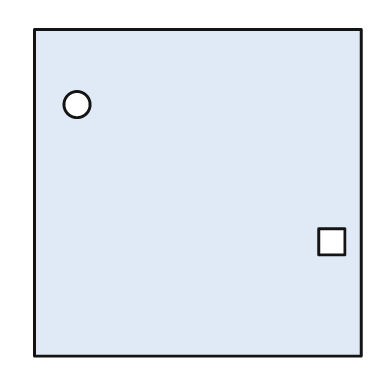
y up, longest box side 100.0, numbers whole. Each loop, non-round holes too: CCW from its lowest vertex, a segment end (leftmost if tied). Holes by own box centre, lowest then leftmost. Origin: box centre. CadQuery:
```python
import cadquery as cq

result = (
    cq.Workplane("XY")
    .moveTo(-50.0, -50.0)
    .lineTo(50.0, -50.0)
    .lineTo(50.0, 50.0)
    .lineTo(-50.0, 50.0)
    .close()
    .moveTo(37.0, -19.0)
    .lineTo(45.0, -19.0)
    .lineTo(45.0, -11.0)
    .lineTo(37.0, -11.0)
    .close()
    .moveTo(-37.0, 27.0)
    .circle(4.0)
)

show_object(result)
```